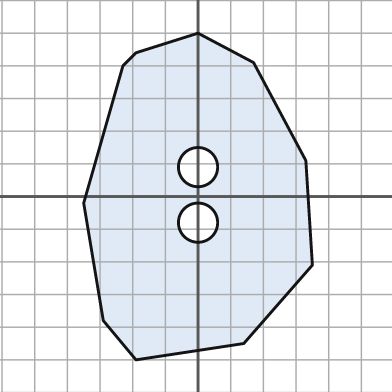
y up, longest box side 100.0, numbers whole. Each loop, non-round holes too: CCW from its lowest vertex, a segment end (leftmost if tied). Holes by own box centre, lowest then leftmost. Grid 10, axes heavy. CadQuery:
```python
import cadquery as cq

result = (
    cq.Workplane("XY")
    .moveTo(-19.0, -50.0)
    .lineTo(14.0, -45.0)
    .lineTo(35.0, -21.0)
    .lineTo(33.0, 11.0)
    .lineTo(17.0, 41.0)
    .lineTo(0.0, 50.0)
    .lineTo(-19.0, 44.0)
    .lineTo(-23.0, 40.0)
    .lineTo(-35.0, -2.0)
    .lineTo(-29.0, -38.0)
    .close()
    .moveTo(0.0, -8.0)
    .circle(6.0)
    .moveTo(0.0, 9.0)
    .circle(6.0)
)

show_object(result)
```